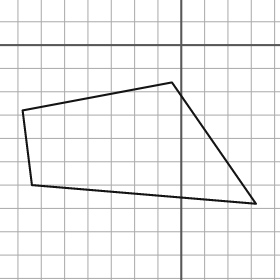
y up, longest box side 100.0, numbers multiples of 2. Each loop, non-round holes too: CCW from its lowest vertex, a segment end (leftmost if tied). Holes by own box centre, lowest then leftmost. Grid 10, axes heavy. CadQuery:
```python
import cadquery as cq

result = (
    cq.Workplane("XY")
    .moveTo(32.0, -68.0)
    .lineTo(-4.0, -16.0)
    .lineTo(-68.0, -28.0)
    .lineTo(-64.0, -60.0)
    .close()
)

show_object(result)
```